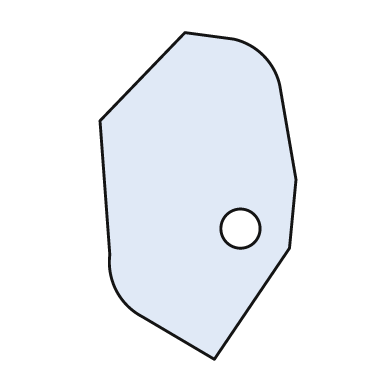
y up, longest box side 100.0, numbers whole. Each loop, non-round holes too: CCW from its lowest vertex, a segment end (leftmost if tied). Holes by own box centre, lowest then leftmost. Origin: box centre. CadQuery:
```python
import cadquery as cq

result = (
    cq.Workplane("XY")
    .moveTo(5.0, -50.0)
    .lineTo(28.0, -16.0)
    .lineTo(30.0, 5.0)
    .lineTo(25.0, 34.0)
    .threePointArc((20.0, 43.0), (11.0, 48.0))
    .lineTo(-4.0, 50.0)
    .lineTo(-30.0, 23.0)
    .lineTo(-27.0, -18.0)
    .threePointArc((-25.0, -29.0), (-17.0, -37.0))
    .close()
    .moveTo(13.0, -10.0)
    .circle(6.0)
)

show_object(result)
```